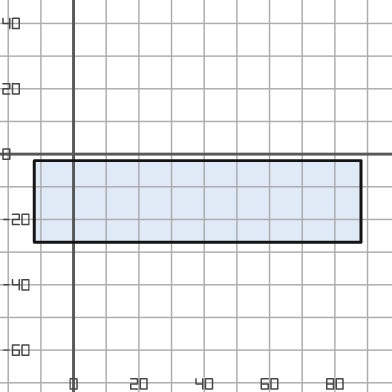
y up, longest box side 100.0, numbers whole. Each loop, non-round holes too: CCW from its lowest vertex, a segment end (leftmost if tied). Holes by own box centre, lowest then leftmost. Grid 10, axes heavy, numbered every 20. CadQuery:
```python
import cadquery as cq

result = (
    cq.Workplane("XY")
    .moveTo(-12.0, -27.0)
    .lineTo(88.0, -27.0)
    .lineTo(88.0, -2.0)
    .lineTo(-12.0, -2.0)
    .close()
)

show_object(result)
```